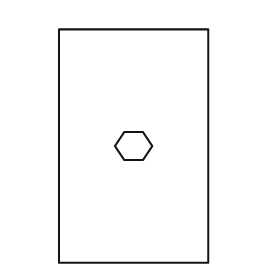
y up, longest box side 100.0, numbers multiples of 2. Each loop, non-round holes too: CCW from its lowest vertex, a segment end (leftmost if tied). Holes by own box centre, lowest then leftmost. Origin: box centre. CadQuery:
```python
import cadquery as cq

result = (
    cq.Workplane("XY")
    .moveTo(-32.0, -50.0)
    .lineTo(32.0, -50.0)
    .lineTo(32.0, 50.0)
    .lineTo(-32.0, 50.0)
    .close()
    .moveTo(-4.0, -6.0)
    .lineTo(4.0, -6.0)
    .lineTo(8.0, 0.0)
    .lineTo(4.0, 6.0)
    .lineTo(-4.0, 6.0)
    .lineTo(-8.0, 0.0)
    .close()
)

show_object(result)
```